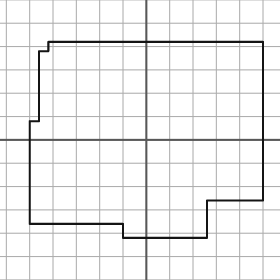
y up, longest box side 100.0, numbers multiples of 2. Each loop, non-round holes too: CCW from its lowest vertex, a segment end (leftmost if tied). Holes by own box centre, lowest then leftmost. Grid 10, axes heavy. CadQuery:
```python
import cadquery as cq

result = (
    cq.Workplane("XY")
    .moveTo(-10.0, -42.0)
    .lineTo(26.0, -42.0)
    .lineTo(26.0, -26.0)
    .lineTo(50.0, -26.0)
    .lineTo(50.0, 42.0)
    .lineTo(-42.0, 42.0)
    .lineTo(-42.0, 38.0)
    .lineTo(-46.0, 38.0)
    .lineTo(-46.0, 8.0)
    .lineTo(-50.0, 8.0)
    .lineTo(-50.0, -36.0)
    .lineTo(-10.0, -36.0)
    .close()
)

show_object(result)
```